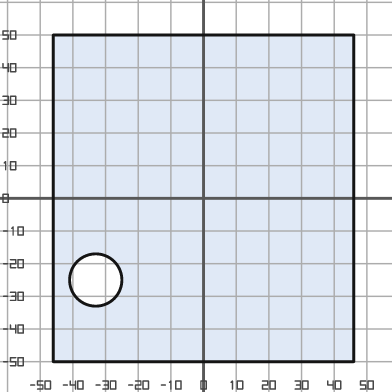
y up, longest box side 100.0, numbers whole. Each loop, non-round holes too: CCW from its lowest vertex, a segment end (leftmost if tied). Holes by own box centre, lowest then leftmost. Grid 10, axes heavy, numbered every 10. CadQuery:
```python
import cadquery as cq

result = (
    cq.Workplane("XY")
    .moveTo(-46.0, -50.0)
    .lineTo(46.0, -50.0)
    .lineTo(46.0, 50.0)
    .lineTo(-46.0, 50.0)
    .close()
    .moveTo(-33.0, -25.0)
    .circle(8.0)
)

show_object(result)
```